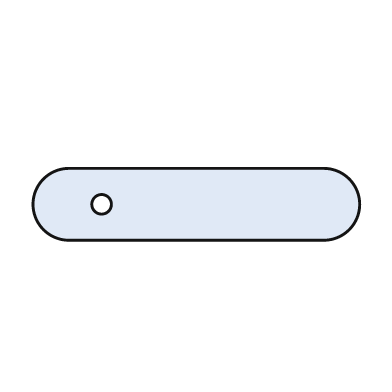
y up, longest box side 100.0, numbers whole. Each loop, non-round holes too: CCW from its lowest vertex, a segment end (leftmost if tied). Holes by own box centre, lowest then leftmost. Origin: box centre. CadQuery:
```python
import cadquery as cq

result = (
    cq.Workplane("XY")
    .moveTo(-39.0, -11.0)
    .lineTo(39.0, -11.0)
    .threePointArc((50.0, 0.0), (39.0, 11.0))
    .lineTo(-39.0, 11.0)
    .threePointArc((-50.0, 0.0), (-39.0, -11.0))
    .close()
    .moveTo(-29.0, 0.0)
    .circle(3.0)
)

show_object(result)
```